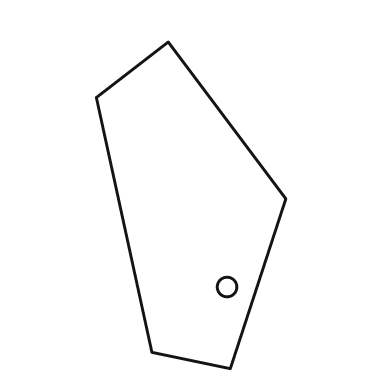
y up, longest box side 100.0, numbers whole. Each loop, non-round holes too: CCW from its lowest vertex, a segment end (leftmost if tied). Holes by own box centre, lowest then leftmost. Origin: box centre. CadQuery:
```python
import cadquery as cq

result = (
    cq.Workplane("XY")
    .moveTo(12.0, -50.0)
    .lineTo(29.0, 2.0)
    .lineTo(-7.0, 50.0)
    .lineTo(-29.0, 33.0)
    .lineTo(-12.0, -45.0)
    .close()
    .moveTo(11.0, -25.0)
    .circle(3.0)
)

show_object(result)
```